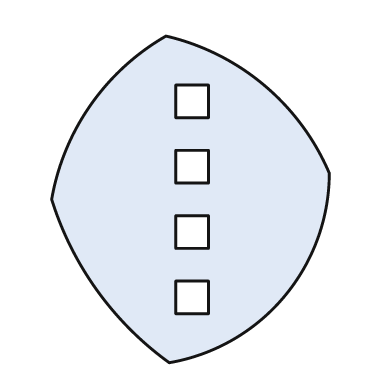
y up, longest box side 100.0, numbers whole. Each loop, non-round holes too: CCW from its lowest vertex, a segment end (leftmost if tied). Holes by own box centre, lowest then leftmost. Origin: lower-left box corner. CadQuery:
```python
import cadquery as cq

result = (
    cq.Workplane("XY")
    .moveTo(36.0, 0.0)
    .threePointArc((71.0, 20.0), (85.0, 58.0))
    .threePointArc((65.0, 85.0), (35.0, 100.0))
    .threePointArc((12.0, 79.0), (0.0, 50.0))
    .threePointArc((14.0, 22.0), (36.0, 0.0))
    .close()
    .moveTo(38.0, 15.0)
    .lineTo(48.0, 15.0)
    .lineTo(48.0, 25.0)
    .lineTo(38.0, 25.0)
    .close()
    .moveTo(38.0, 35.0)
    .lineTo(48.0, 35.0)
    .lineTo(48.0, 45.0)
    .lineTo(38.0, 45.0)
    .close()
    .moveTo(38.0, 55.0)
    .lineTo(48.0, 55.0)
    .lineTo(48.0, 65.0)
    .lineTo(38.0, 65.0)
    .close()
    .moveTo(38.0, 75.0)
    .lineTo(48.0, 75.0)
    .lineTo(48.0, 85.0)
    .lineTo(38.0, 85.0)
    .close()
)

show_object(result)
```